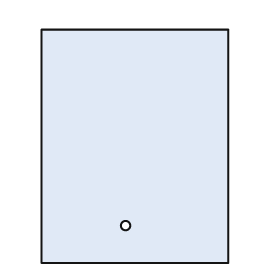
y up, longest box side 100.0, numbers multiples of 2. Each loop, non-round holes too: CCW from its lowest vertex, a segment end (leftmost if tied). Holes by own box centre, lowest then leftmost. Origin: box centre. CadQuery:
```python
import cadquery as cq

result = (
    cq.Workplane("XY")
    .moveTo(-40.0, -50.0)
    .lineTo(40.0, -50.0)
    .lineTo(40.0, 50.0)
    .lineTo(-40.0, 50.0)
    .close()
    .moveTo(-4.0, -34.0)
    .circle(2.0)
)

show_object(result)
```